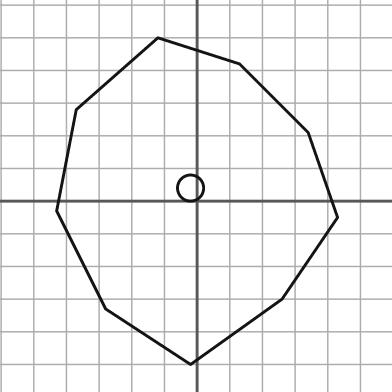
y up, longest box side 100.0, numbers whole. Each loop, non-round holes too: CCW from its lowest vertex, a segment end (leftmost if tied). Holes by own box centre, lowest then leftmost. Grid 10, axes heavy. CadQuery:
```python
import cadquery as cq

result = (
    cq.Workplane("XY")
    .moveTo(-2.0, -50.0)
    .lineTo(26.0, -30.0)
    .lineTo(43.0, -5.0)
    .lineTo(34.0, 21.0)
    .lineTo(13.0, 42.0)
    .lineTo(-12.0, 50.0)
    .lineTo(-37.0, 28.0)
    .lineTo(-43.0, -3.0)
    .lineTo(-28.0, -33.0)
    .close()
    .moveTo(-2.0, 4.0)
    .circle(4.0)
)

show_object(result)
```